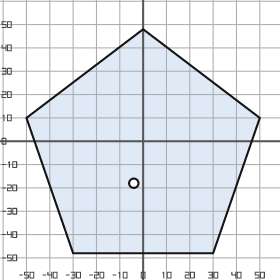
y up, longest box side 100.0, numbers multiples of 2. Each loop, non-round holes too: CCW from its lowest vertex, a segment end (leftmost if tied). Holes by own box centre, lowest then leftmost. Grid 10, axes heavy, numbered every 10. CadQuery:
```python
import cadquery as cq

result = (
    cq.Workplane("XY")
    .moveTo(-30.0, -48.0)
    .lineTo(30.0, -48.0)
    .lineTo(50.0, 10.0)
    .lineTo(0.0, 48.0)
    .lineTo(-50.0, 10.0)
    .close()
    .moveTo(-4.0, -18.0)
    .circle(2.0)
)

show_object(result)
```